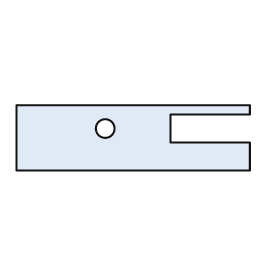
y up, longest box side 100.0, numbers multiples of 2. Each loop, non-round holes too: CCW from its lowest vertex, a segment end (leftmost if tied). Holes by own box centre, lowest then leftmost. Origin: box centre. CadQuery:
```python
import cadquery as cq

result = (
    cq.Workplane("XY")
    .moveTo(-50.0, -14.0)
    .lineTo(50.0, -14.0)
    .lineTo(50.0, -2.0)
    .lineTo(16.0, -2.0)
    .lineTo(16.0, 10.0)
    .lineTo(50.0, 10.0)
    .lineTo(50.0, 14.0)
    .lineTo(-50.0, 14.0)
    .close()
    .moveTo(-12.0, 4.0)
    .circle(4.0)
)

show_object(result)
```